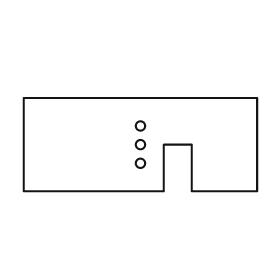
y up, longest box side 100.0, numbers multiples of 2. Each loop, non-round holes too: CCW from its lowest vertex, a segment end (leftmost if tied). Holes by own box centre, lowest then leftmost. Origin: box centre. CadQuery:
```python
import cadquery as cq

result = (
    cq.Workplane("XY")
    .moveTo(-50.0, -20.0)
    .lineTo(10.0, -20.0)
    .lineTo(10.0, 0.0)
    .lineTo(22.0, 0.0)
    .lineTo(22.0, -20.0)
    .lineTo(50.0, -20.0)
    .lineTo(50.0, 20.0)
    .lineTo(-50.0, 20.0)
    .close()
    .moveTo(0.0, -8.0)
    .circle(2.0)
    .moveTo(0.0, 0.0)
    .circle(2.0)
    .moveTo(0.0, 8.0)
    .circle(2.0)
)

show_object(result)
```